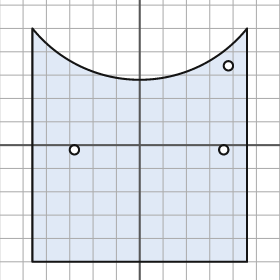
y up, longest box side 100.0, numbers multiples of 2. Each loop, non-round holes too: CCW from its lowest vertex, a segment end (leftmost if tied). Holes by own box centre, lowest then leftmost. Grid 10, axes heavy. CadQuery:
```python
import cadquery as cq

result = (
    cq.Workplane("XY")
    .moveTo(-46.0, -50.0)
    .lineTo(46.0, -50.0)
    .lineTo(46.0, 50.0)
    .threePointArc((0.0, 28.0), (-46.0, 50.0))
    .close()
    .moveTo(-28.0, -2.0)
    .circle(2.0)
    .moveTo(36.0, -2.0)
    .circle(2.0)
    .moveTo(38.0, 34.0)
    .circle(2.0)
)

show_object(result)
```